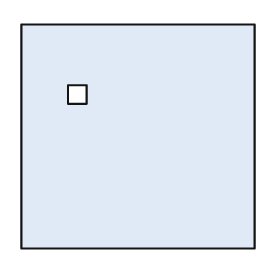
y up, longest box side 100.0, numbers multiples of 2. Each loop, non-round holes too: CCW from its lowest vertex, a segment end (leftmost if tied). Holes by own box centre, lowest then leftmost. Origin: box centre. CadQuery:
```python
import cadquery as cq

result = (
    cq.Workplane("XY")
    .moveTo(-50.0, -48.0)
    .lineTo(50.0, -48.0)
    .lineTo(50.0, 48.0)
    .lineTo(-50.0, 48.0)
    .close()
    .moveTo(-30.0, 14.0)
    .lineTo(-22.0, 14.0)
    .lineTo(-22.0, 22.0)
    .lineTo(-30.0, 22.0)
    .close()
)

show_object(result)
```